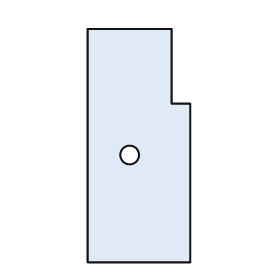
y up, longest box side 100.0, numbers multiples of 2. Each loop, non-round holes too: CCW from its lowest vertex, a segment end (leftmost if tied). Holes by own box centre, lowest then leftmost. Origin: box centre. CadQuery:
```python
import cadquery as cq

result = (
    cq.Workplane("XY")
    .moveTo(-22.0, -50.0)
    .lineTo(22.0, -50.0)
    .lineTo(22.0, 18.0)
    .lineTo(14.0, 18.0)
    .lineTo(14.0, 50.0)
    .lineTo(-22.0, 50.0)
    .close()
    .moveTo(-4.0, -4.0)
    .circle(4.0)
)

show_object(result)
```